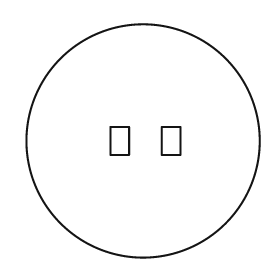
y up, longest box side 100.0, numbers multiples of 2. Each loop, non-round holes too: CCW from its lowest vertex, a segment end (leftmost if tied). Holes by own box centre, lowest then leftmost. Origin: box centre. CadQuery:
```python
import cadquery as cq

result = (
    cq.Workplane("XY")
    .moveTo(0.0, 0.0)
    .circle(50.0)
    .moveTo(-14.0, -6.0)
    .lineTo(-6.0, -6.0)
    .lineTo(-6.0, 6.0)
    .lineTo(-14.0, 6.0)
    .close()
    .moveTo(8.0, -6.0)
    .lineTo(16.0, -6.0)
    .lineTo(16.0, 6.0)
    .lineTo(8.0, 6.0)
    .close()
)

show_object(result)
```